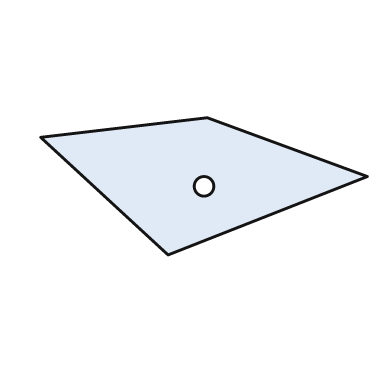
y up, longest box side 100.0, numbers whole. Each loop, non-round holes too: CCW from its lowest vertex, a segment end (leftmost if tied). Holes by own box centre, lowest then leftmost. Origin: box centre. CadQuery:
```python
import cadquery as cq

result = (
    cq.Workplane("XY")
    .moveTo(-11.0, -21.0)
    .lineTo(50.0, 3.0)
    .lineTo(1.0, 21.0)
    .lineTo(-50.0, 15.0)
    .close()
    .moveTo(0.0, 0.0)
    .circle(3.0)
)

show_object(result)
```